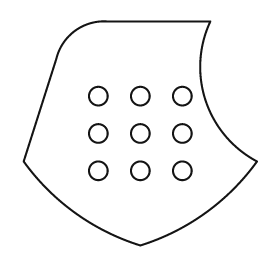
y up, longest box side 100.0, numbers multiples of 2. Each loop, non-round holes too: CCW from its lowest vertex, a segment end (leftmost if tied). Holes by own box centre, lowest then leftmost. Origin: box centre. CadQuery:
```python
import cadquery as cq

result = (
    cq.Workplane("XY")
    .moveTo(0.0, -48.0)
    .threePointArc((28.0, -34.0), (50.0, -12.0))
    .threePointArc((28.0, 14.0), (30.0, 48.0))
    .lineTo(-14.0, 48.0)
    .threePointArc((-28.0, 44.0), (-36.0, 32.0))
    .lineTo(-50.0, -12.0)
    .threePointArc((-28.0, -34.0), (0.0, -48.0))
    .close()
    .moveTo(-18.0, -16.0)
    .circle(4.0)
    .moveTo(0.0, -16.0)
    .circle(4.0)
    .moveTo(18.0, -16.0)
    .circle(4.0)
    .moveTo(-18.0, 0.0)
    .circle(4.0)
    .moveTo(0.0, 0.0)
    .circle(4.0)
    .moveTo(18.0, 0.0)
    .circle(4.0)
    .moveTo(-18.0, 16.0)
    .circle(4.0)
    .moveTo(0.0, 16.0)
    .circle(4.0)
    .moveTo(18.0, 16.0)
    .circle(4.0)
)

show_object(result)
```